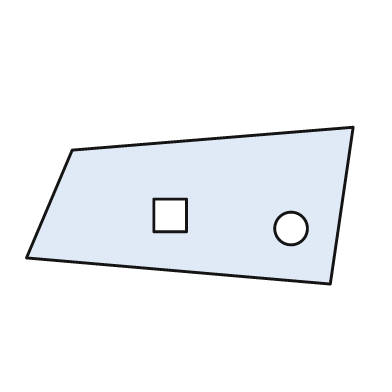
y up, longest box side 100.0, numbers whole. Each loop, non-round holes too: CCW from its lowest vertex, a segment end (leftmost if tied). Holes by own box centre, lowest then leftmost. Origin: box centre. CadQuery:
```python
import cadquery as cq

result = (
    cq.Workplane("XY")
    .moveTo(43.0, -24.0)
    .lineTo(50.0, 24.0)
    .lineTo(-36.0, 17.0)
    .lineTo(-50.0, -16.0)
    .close()
    .moveTo(31.0, -7.0)
    .circle(5.0)
    .moveTo(-11.0, -8.0)
    .lineTo(-1.0, -8.0)
    .lineTo(-1.0, 2.0)
    .lineTo(-11.0, 2.0)
    .close()
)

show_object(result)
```